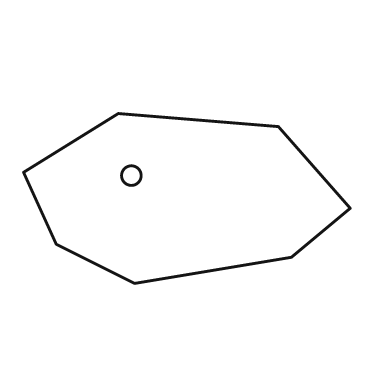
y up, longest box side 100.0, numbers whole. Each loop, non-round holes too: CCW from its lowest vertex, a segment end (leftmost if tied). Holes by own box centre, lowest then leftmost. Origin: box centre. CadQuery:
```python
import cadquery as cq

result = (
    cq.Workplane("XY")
    .moveTo(-16.0, -26.0)
    .lineTo(32.0, -18.0)
    .lineTo(50.0, -3.0)
    .lineTo(28.0, 22.0)
    .lineTo(-21.0, 26.0)
    .lineTo(-50.0, 8.0)
    .lineTo(-40.0, -14.0)
    .close()
    .moveTo(-17.0, 7.0)
    .circle(3.0)
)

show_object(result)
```